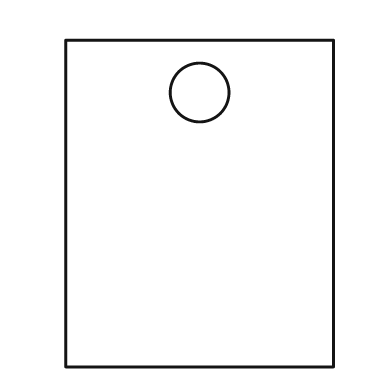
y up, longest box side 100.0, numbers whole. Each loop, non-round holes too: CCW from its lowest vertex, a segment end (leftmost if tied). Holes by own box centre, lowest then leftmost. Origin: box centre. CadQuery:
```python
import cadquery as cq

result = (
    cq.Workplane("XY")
    .moveTo(-41.0, -50.0)
    .lineTo(41.0, -50.0)
    .lineTo(41.0, 50.0)
    .lineTo(-41.0, 50.0)
    .close()
    .moveTo(0.0, 34.0)
    .circle(9.0)
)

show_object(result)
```